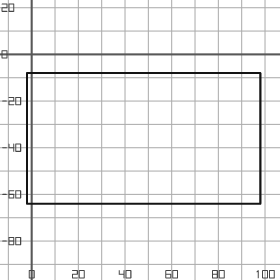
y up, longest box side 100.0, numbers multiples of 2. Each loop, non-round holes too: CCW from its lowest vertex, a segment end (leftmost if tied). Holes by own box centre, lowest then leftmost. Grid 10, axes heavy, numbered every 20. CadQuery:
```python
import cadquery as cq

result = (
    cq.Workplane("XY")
    .moveTo(-2.0, -64.0)
    .lineTo(98.0, -64.0)
    .lineTo(98.0, -8.0)
    .lineTo(-2.0, -8.0)
    .close()
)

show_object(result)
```